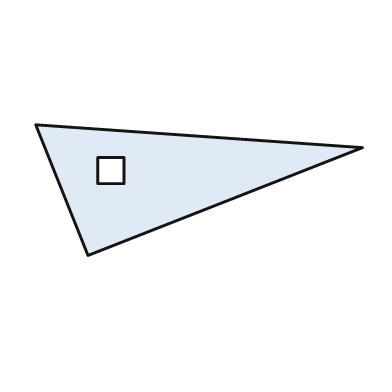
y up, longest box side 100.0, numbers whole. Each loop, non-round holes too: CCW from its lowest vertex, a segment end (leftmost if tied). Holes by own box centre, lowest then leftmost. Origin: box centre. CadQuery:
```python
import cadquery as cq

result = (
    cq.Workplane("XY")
    .moveTo(-34.0, -20.0)
    .lineTo(50.0, 13.0)
    .lineTo(-50.0, 20.0)
    .close()
    .moveTo(-31.0, 2.0)
    .lineTo(-23.0, 2.0)
    .lineTo(-23.0, 10.0)
    .lineTo(-31.0, 10.0)
    .close()
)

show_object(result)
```